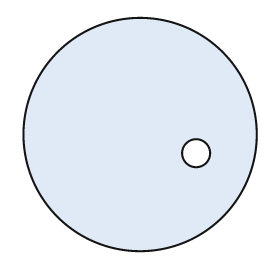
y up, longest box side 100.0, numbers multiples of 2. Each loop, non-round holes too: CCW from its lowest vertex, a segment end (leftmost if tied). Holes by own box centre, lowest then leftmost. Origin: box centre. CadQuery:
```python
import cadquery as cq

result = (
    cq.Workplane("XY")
    .moveTo(0.0, 0.0)
    .circle(50.0)
    .moveTo(24.0, -8.0)
    .circle(6.0)
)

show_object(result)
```